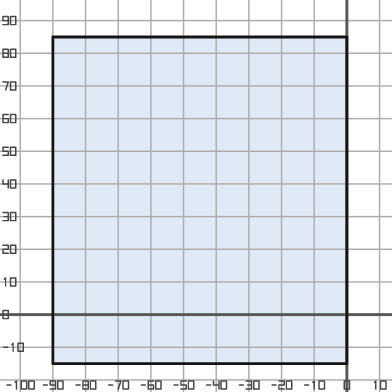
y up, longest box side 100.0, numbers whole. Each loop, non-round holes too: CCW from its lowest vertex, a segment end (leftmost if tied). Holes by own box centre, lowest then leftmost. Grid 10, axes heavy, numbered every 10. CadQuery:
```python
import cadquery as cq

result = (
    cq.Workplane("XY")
    .moveTo(-90.0, -15.0)
    .lineTo(0.0, -15.0)
    .lineTo(0.0, 85.0)
    .lineTo(-90.0, 85.0)
    .close()
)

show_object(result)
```